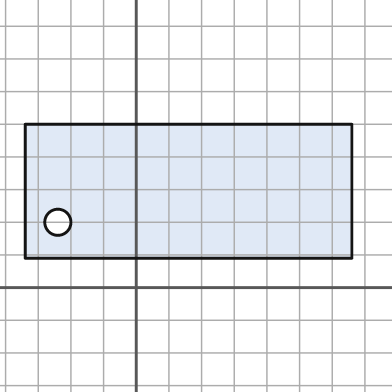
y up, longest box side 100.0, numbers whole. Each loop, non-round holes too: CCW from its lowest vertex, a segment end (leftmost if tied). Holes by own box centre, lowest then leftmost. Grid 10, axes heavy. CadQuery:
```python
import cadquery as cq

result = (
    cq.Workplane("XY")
    .moveTo(-34.0, 9.0)
    .lineTo(66.0, 9.0)
    .lineTo(66.0, 50.0)
    .lineTo(-34.0, 50.0)
    .close()
    .moveTo(-24.0, 20.0)
    .circle(4.0)
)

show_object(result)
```